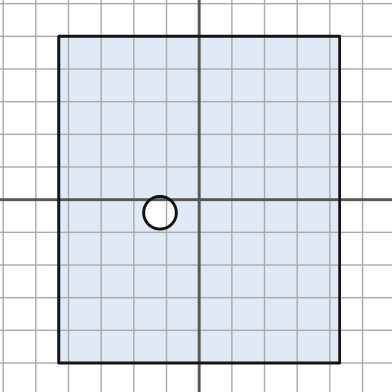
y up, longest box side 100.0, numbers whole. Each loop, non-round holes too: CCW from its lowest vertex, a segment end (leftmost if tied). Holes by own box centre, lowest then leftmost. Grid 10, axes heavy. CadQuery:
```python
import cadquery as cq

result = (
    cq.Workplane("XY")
    .moveTo(-43.0, -50.0)
    .lineTo(43.0, -50.0)
    .lineTo(43.0, 50.0)
    .lineTo(-43.0, 50.0)
    .close()
    .moveTo(-12.0, -4.0)
    .circle(5.0)
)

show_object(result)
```